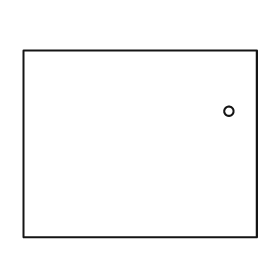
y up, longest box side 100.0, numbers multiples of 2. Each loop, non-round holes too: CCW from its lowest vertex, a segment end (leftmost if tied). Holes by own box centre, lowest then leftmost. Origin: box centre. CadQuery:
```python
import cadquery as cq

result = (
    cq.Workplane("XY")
    .moveTo(-50.0, -40.0)
    .lineTo(50.0, -40.0)
    .lineTo(50.0, 40.0)
    .lineTo(-50.0, 40.0)
    .close()
    .moveTo(38.0, 14.0)
    .circle(2.0)
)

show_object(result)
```